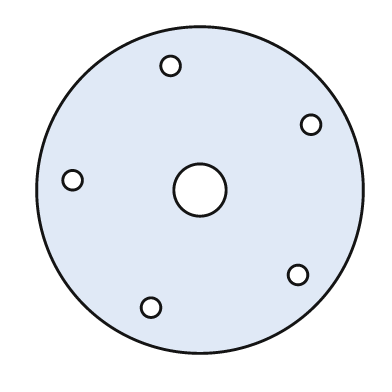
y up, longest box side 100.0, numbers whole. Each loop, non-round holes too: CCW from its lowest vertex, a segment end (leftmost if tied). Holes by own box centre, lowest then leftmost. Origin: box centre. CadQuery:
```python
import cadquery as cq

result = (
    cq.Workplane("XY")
    .moveTo(0.0, 0.0)
    .circle(50.0)
    .moveTo(-15.0, -36.0)
    .circle(3.0)
    .moveTo(30.0, -26.0)
    .circle(3.0)
    .moveTo(0.0, 0.0)
    .circle(8.0)
    .moveTo(-39.0, 3.0)
    .circle(3.0)
    .moveTo(34.0, 20.0)
    .circle(3.0)
    .moveTo(-9.0, 38.0)
    .circle(3.0)
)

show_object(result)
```